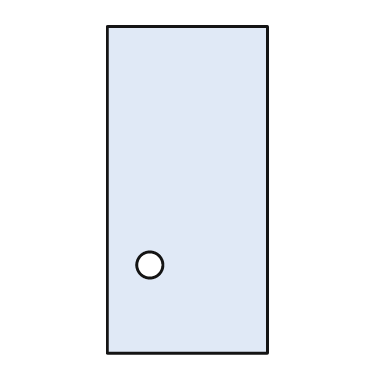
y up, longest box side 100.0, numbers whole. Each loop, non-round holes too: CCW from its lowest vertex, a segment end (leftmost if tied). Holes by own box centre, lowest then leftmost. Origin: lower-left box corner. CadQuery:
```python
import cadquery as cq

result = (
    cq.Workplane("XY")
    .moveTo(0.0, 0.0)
    .lineTo(49.0, 0.0)
    .lineTo(49.0, 100.0)
    .lineTo(0.0, 100.0)
    .close()
    .moveTo(13.0, 27.0)
    .circle(4.0)
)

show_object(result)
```